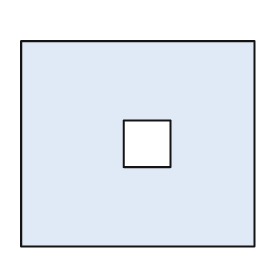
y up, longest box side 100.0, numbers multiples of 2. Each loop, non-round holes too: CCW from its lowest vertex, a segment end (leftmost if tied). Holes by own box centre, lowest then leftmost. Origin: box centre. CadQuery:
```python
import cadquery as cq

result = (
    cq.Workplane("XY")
    .moveTo(-50.0, -44.0)
    .lineTo(50.0, -44.0)
    .lineTo(50.0, 44.0)
    .lineTo(-50.0, 44.0)
    .close()
    .moveTo(-6.0, -10.0)
    .lineTo(14.0, -10.0)
    .lineTo(14.0, 10.0)
    .lineTo(-6.0, 10.0)
    .close()
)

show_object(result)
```